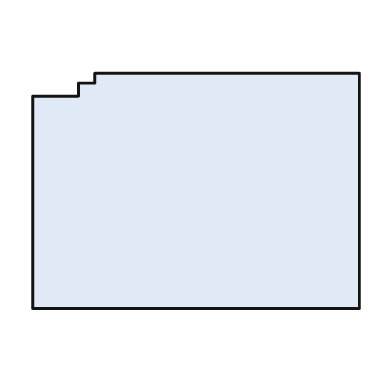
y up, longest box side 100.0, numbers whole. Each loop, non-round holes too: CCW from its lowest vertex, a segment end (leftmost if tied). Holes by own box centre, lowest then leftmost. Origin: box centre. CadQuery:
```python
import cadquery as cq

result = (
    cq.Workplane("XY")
    .moveTo(-50.0, -36.0)
    .lineTo(50.0, -36.0)
    .lineTo(50.0, 36.0)
    .lineTo(-31.0, 36.0)
    .lineTo(-31.0, 33.0)
    .lineTo(-36.0, 33.0)
    .lineTo(-36.0, 29.0)
    .lineTo(-50.0, 29.0)
    .close()
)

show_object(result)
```